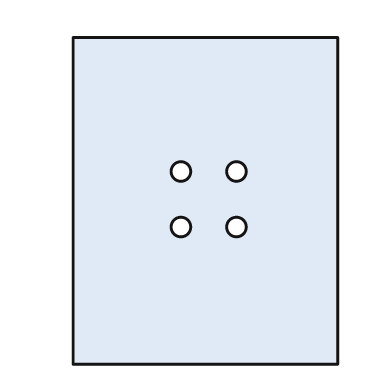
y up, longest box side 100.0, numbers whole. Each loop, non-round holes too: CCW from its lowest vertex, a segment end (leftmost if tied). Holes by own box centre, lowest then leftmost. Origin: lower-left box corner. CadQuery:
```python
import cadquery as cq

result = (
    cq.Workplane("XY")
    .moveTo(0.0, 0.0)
    .lineTo(81.0, 0.0)
    .lineTo(81.0, 100.0)
    .lineTo(0.0, 100.0)
    .close()
    .moveTo(33.0, 42.0)
    .circle(3.0)
    .moveTo(50.0, 42.0)
    .circle(3.0)
    .moveTo(33.0, 59.0)
    .circle(3.0)
    .moveTo(50.0, 59.0)
    .circle(3.0)
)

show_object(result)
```